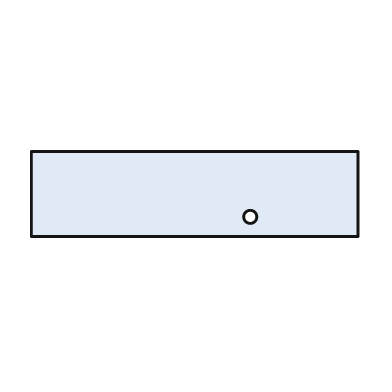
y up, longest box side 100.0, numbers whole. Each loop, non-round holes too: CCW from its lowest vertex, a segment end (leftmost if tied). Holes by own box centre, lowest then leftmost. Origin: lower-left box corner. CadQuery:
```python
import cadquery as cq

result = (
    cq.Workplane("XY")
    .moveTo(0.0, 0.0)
    .lineTo(100.0, 0.0)
    .lineTo(100.0, 26.0)
    .lineTo(0.0, 26.0)
    .close()
    .moveTo(67.0, 6.0)
    .circle(2.0)
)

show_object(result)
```